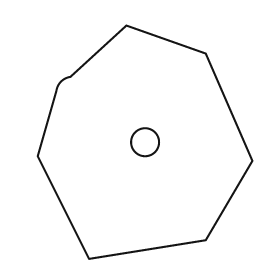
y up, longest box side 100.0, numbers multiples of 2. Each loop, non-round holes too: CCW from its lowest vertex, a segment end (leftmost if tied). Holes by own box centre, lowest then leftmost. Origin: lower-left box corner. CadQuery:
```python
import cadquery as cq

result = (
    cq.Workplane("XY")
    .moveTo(22.0, 0.0)
    .lineTo(72.0, 8.0)
    .lineTo(92.0, 42.0)
    .lineTo(72.0, 88.0)
    .lineTo(38.0, 100.0)
    .lineTo(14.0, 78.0)
    .threePointArc((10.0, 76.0), (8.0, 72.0))
    .lineTo(0.0, 44.0)
    .close()
    .moveTo(46.0, 50.0)
    .circle(6.0)
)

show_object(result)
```